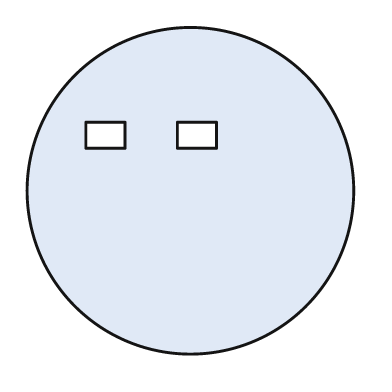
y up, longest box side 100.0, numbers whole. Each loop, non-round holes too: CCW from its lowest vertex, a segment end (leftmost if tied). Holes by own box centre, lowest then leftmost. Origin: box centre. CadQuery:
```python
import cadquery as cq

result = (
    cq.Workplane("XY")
    .moveTo(0.0, 0.0)
    .circle(50.0)
    .moveTo(-32.0, 13.0)
    .lineTo(-20.0, 13.0)
    .lineTo(-20.0, 21.0)
    .lineTo(-32.0, 21.0)
    .close()
    .moveTo(-4.0, 13.0)
    .lineTo(8.0, 13.0)
    .lineTo(8.0, 21.0)
    .lineTo(-4.0, 21.0)
    .close()
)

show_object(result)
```